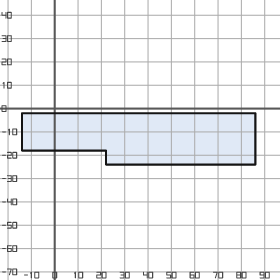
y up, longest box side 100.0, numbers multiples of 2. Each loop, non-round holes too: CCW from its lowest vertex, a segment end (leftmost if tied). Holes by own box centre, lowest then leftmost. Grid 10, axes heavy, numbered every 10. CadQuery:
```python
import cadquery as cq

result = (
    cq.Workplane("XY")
    .moveTo(22.0, -24.0)
    .lineTo(86.0, -24.0)
    .lineTo(86.0, -2.0)
    .lineTo(-14.0, -2.0)
    .lineTo(-14.0, -18.0)
    .lineTo(22.0, -18.0)
    .close()
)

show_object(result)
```